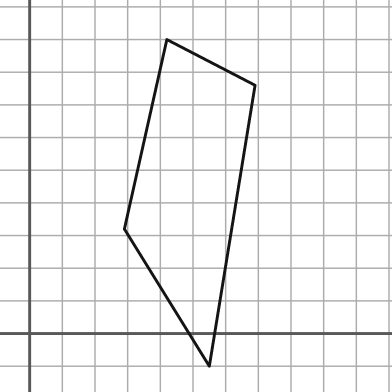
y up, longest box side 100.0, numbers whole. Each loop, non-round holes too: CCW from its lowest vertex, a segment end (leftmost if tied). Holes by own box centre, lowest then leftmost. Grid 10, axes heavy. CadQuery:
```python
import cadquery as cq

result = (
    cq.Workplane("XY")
    .moveTo(55.0, -10.0)
    .lineTo(69.0, 76.0)
    .lineTo(42.0, 90.0)
    .lineTo(29.0, 32.0)
    .close()
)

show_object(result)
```